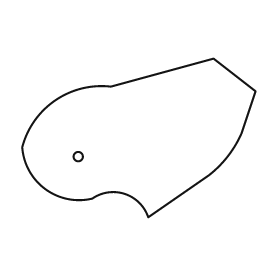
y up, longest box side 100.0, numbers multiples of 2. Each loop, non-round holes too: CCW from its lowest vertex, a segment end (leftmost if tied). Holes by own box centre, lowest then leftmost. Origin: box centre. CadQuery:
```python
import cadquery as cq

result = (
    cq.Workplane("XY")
    .moveTo(4.0, -34.0)
    .lineTo(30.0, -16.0)
    .threePointArc((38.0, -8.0), (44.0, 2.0))
    .lineTo(50.0, 20.0)
    .lineTo(32.0, 34.0)
    .lineTo(-12.0, 22.0)
    .threePointArc((-36.0, 16.0), (-50.0, -4.0))
    .threePointArc((-40.0, -22.0), (-20.0, -26.0))
    .threePointArc((-6.0, -24.0), (4.0, -34.0))
    .close()
    .moveTo(-26.0, -8.0)
    .circle(2.0)
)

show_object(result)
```